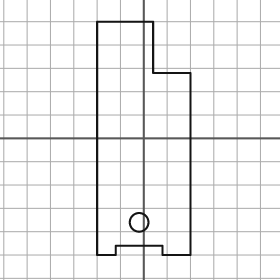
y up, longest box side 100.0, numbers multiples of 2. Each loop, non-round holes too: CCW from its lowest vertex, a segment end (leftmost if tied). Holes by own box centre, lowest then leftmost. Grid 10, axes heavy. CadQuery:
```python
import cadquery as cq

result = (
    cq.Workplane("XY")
    .moveTo(-20.0, -50.0)
    .lineTo(-12.0, -50.0)
    .lineTo(-12.0, -46.0)
    .lineTo(8.0, -46.0)
    .lineTo(8.0, -50.0)
    .lineTo(20.0, -50.0)
    .lineTo(20.0, 28.0)
    .lineTo(4.0, 28.0)
    .lineTo(4.0, 50.0)
    .lineTo(-20.0, 50.0)
    .close()
    .moveTo(-2.0, -36.0)
    .circle(4.0)
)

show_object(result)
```